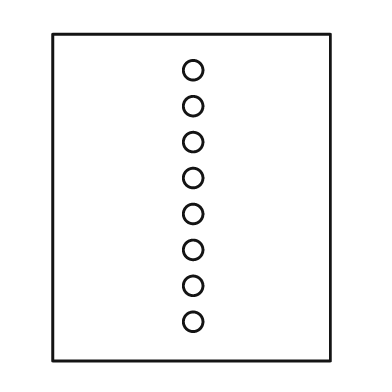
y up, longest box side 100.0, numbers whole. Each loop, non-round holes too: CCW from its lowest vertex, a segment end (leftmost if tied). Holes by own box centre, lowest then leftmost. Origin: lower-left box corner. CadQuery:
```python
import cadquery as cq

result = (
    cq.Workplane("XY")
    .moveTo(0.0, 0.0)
    .lineTo(85.0, 0.0)
    .lineTo(85.0, 100.0)
    .lineTo(0.0, 100.0)
    .close()
    .moveTo(43.0, 12.0)
    .circle(3.0)
    .moveTo(43.0, 23.0)
    .circle(3.0)
    .moveTo(43.0, 34.0)
    .circle(3.0)
    .moveTo(43.0, 45.0)
    .circle(3.0)
    .moveTo(43.0, 56.0)
    .circle(3.0)
    .moveTo(43.0, 67.0)
    .circle(3.0)
    .moveTo(43.0, 78.0)
    .circle(3.0)
    .moveTo(43.0, 89.0)
    .circle(3.0)
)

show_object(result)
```